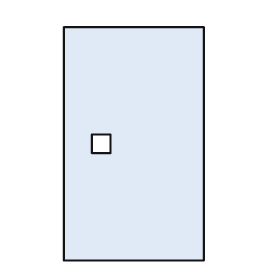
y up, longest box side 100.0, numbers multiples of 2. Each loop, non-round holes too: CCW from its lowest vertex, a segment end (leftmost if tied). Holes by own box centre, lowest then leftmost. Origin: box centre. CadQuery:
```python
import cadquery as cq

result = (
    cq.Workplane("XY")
    .moveTo(-30.0, -50.0)
    .lineTo(30.0, -50.0)
    .lineTo(30.0, 50.0)
    .lineTo(-30.0, 50.0)
    .close()
    .moveTo(-18.0, -4.0)
    .lineTo(-10.0, -4.0)
    .lineTo(-10.0, 4.0)
    .lineTo(-18.0, 4.0)
    .close()
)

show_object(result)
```